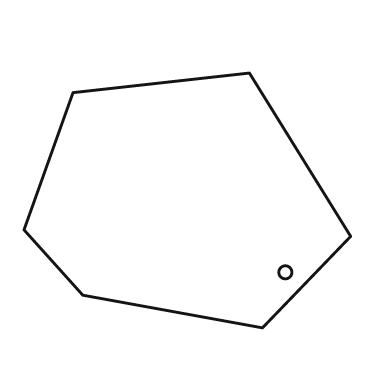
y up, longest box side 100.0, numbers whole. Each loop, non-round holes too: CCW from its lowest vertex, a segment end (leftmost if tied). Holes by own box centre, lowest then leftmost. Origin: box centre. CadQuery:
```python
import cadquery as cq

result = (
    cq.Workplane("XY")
    .moveTo(23.0, -39.0)
    .lineTo(50.0, -11.0)
    .lineTo(19.0, 39.0)
    .lineTo(-35.0, 33.0)
    .lineTo(-50.0, -9.0)
    .lineTo(-32.0, -29.0)
    .close()
    .moveTo(30.0, -22.0)
    .circle(2.0)
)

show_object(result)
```